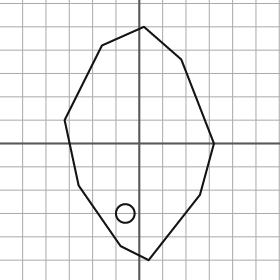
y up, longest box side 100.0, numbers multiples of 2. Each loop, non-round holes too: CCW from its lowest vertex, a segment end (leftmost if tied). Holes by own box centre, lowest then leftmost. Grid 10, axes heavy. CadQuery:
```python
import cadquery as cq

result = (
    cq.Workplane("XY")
    .moveTo(4.0, -50.0)
    .lineTo(26.0, -22.0)
    .lineTo(32.0, 0.0)
    .lineTo(18.0, 36.0)
    .lineTo(2.0, 50.0)
    .lineTo(-16.0, 42.0)
    .lineTo(-32.0, 10.0)
    .lineTo(-26.0, -18.0)
    .lineTo(-8.0, -44.0)
    .close()
    .moveTo(-6.0, -30.0)
    .circle(4.0)
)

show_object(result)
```